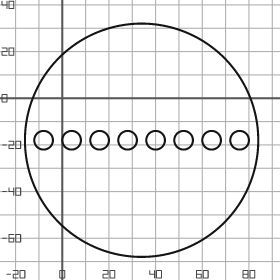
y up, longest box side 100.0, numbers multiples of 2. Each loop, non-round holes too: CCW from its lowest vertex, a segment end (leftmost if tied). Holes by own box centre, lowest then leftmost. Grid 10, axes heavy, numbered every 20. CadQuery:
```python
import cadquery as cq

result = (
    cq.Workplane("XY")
    .moveTo(34.0, -18.0)
    .circle(50.0)
    .moveTo(-8.0, -18.0)
    .circle(4.0)
    .moveTo(4.0, -18.0)
    .circle(4.0)
    .moveTo(16.0, -18.0)
    .circle(4.0)
    .moveTo(28.0, -18.0)
    .circle(4.0)
    .moveTo(40.0, -18.0)
    .circle(4.0)
    .moveTo(52.0, -18.0)
    .circle(4.0)
    .moveTo(64.0, -18.0)
    .circle(4.0)
    .moveTo(76.0, -18.0)
    .circle(4.0)
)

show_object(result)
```